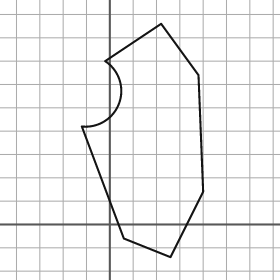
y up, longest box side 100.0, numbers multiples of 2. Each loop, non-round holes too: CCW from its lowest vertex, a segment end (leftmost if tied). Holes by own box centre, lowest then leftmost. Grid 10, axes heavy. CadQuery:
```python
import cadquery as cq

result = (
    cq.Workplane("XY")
    .moveTo(26.0, -14.0)
    .lineTo(40.0, 14.0)
    .lineTo(38.0, 64.0)
    .lineTo(22.0, 86.0)
    .lineTo(-2.0, 70.0)
    .threePointArc((4.0, 52.0), (-12.0, 42.0))
    .lineTo(6.0, -6.0)
    .close()
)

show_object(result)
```